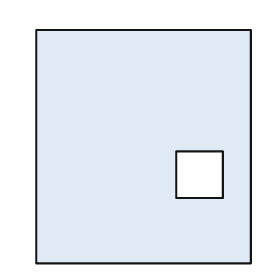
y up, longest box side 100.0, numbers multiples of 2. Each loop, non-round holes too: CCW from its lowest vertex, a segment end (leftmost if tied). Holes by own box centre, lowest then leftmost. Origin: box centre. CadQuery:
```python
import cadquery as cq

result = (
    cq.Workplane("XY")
    .moveTo(-46.0, -50.0)
    .lineTo(46.0, -50.0)
    .lineTo(46.0, 50.0)
    .lineTo(-46.0, 50.0)
    .close()
    .moveTo(14.0, -22.0)
    .lineTo(34.0, -22.0)
    .lineTo(34.0, -2.0)
    .lineTo(14.0, -2.0)
    .close()
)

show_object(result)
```